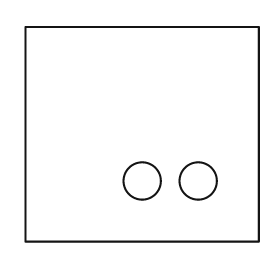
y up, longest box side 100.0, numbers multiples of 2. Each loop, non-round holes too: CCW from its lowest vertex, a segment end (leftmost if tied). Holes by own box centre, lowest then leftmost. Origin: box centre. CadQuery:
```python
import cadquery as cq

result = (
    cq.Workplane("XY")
    .moveTo(-50.0, -46.0)
    .lineTo(50.0, -46.0)
    .lineTo(50.0, 46.0)
    .lineTo(-50.0, 46.0)
    .close()
    .moveTo(0.0, -20.0)
    .circle(8.0)
    .moveTo(24.0, -20.0)
    .circle(8.0)
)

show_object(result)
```